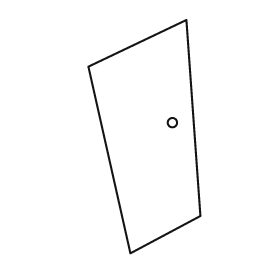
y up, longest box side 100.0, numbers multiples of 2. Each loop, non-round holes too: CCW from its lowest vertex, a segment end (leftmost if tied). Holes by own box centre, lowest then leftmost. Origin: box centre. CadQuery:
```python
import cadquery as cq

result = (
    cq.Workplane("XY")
    .moveTo(-6.0, -50.0)
    .lineTo(24.0, -34.0)
    .lineTo(18.0, 50.0)
    .lineTo(-24.0, 30.0)
    .close()
    .moveTo(12.0, 6.0)
    .circle(2.0)
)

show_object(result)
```